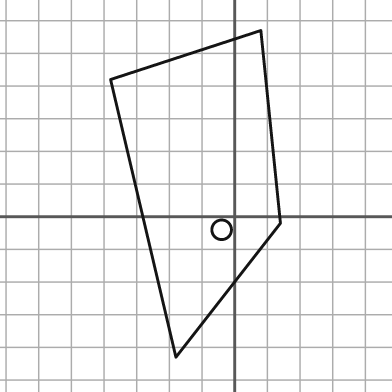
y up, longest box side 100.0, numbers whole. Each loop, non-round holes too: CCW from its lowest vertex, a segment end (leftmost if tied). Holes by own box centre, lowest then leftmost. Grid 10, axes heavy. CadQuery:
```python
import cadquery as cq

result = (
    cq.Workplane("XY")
    .moveTo(-18.0, -43.0)
    .lineTo(14.0, -2.0)
    .lineTo(8.0, 57.0)
    .lineTo(-38.0, 42.0)
    .close()
    .moveTo(-4.0, -4.0)
    .circle(3.0)
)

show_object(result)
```